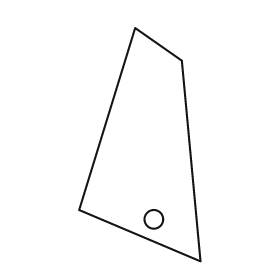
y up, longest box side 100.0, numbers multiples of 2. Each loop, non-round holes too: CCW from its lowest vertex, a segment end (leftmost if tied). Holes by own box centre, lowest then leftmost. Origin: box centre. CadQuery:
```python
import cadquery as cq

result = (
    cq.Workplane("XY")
    .moveTo(26.0, -50.0)
    .lineTo(18.0, 36.0)
    .lineTo(-2.0, 50.0)
    .lineTo(-26.0, -28.0)
    .close()
    .moveTo(6.0, -32.0)
    .circle(4.0)
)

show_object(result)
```